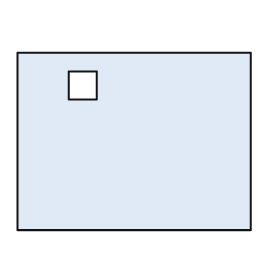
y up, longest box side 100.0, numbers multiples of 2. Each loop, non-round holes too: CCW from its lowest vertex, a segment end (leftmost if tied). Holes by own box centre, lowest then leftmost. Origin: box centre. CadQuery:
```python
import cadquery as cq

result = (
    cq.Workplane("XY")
    .moveTo(-50.0, -38.0)
    .lineTo(50.0, -38.0)
    .lineTo(50.0, 38.0)
    .lineTo(-50.0, 38.0)
    .close()
    .moveTo(-28.0, 18.0)
    .lineTo(-16.0, 18.0)
    .lineTo(-16.0, 30.0)
    .lineTo(-28.0, 30.0)
    .close()
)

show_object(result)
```